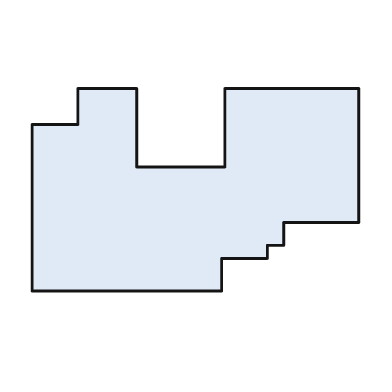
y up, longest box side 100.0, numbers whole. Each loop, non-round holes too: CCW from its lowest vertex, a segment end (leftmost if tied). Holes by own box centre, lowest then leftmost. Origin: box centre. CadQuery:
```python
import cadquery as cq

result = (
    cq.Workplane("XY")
    .moveTo(-50.0, -31.0)
    .lineTo(8.0, -31.0)
    .lineTo(8.0, -21.0)
    .lineTo(22.0, -21.0)
    .lineTo(22.0, -17.0)
    .lineTo(27.0, -17.0)
    .lineTo(27.0, -10.0)
    .lineTo(50.0, -10.0)
    .lineTo(50.0, 31.0)
    .lineTo(9.0, 31.0)
    .lineTo(9.0, 7.0)
    .lineTo(-18.0, 7.0)
    .lineTo(-18.0, 31.0)
    .lineTo(-36.0, 31.0)
    .lineTo(-36.0, 20.0)
    .lineTo(-50.0, 20.0)
    .close()
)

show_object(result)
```